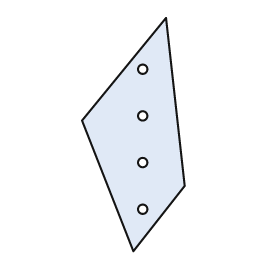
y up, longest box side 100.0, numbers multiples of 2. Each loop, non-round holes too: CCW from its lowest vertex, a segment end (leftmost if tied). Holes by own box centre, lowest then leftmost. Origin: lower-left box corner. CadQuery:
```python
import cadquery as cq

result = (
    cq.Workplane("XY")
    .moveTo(22.0, 0.0)
    .lineTo(44.0, 28.0)
    .lineTo(36.0, 100.0)
    .lineTo(0.0, 56.0)
    .close()
    .moveTo(26.0, 18.0)
    .circle(2.0)
    .moveTo(26.0, 38.0)
    .circle(2.0)
    .moveTo(26.0, 58.0)
    .circle(2.0)
    .moveTo(26.0, 78.0)
    .circle(2.0)
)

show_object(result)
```